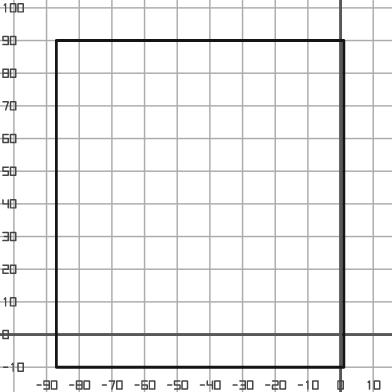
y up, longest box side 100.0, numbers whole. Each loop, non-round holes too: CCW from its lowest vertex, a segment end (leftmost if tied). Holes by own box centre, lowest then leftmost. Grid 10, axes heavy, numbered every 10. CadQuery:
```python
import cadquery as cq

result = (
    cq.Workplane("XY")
    .moveTo(-87.0, -10.0)
    .lineTo(1.0, -10.0)
    .lineTo(1.0, 90.0)
    .lineTo(-87.0, 90.0)
    .close()
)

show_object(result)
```